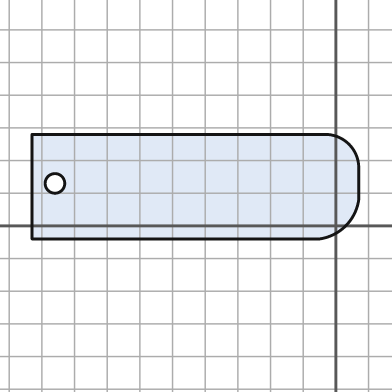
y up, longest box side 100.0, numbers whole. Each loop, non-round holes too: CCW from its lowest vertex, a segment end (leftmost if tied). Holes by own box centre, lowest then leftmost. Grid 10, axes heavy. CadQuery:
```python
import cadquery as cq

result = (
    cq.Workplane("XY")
    .moveTo(-93.0, -4.0)
    .lineTo(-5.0, -4.0)
    .threePointArc((3.0, 0.0), (7.0, 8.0))
    .lineTo(7.0, 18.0)
    .threePointArc((4.0, 25.0), (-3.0, 28.0))
    .lineTo(-93.0, 28.0)
    .close()
    .moveTo(-86.0, 13.0)
    .circle(3.0)
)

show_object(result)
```